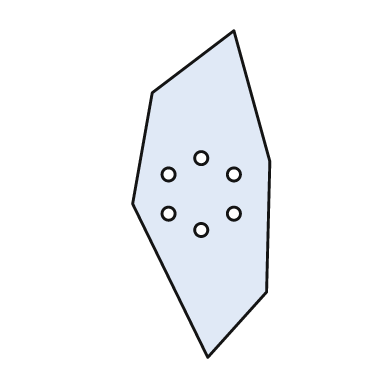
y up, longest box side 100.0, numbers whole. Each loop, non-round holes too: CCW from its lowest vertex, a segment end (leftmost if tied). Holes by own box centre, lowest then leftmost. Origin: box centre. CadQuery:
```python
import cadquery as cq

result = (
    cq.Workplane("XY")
    .moveTo(2.0, -50.0)
    .lineTo(20.0, -30.0)
    .lineTo(21.0, 10.0)
    .lineTo(10.0, 50.0)
    .lineTo(-15.0, 31.0)
    .lineTo(-21.0, -3.0)
    .close()
    .moveTo(0.0, -11.0)
    .circle(2.0)
    .moveTo(-10.0, -6.0)
    .circle(2.0)
    .moveTo(10.0, -6.0)
    .circle(2.0)
    .moveTo(-10.0, 6.0)
    .circle(2.0)
    .moveTo(10.0, 6.0)
    .circle(2.0)
    .moveTo(0.0, 11.0)
    .circle(2.0)
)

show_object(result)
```